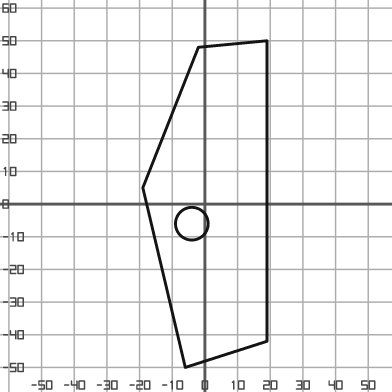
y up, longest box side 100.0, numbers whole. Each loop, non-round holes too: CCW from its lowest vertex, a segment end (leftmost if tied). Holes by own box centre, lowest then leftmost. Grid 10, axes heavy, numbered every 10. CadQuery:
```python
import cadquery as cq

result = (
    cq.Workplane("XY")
    .moveTo(-6.0, -50.0)
    .lineTo(19.0, -42.0)
    .lineTo(19.0, 50.0)
    .lineTo(-2.0, 48.0)
    .lineTo(-19.0, 5.0)
    .close()
    .moveTo(-4.0, -6.0)
    .circle(5.0)
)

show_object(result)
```